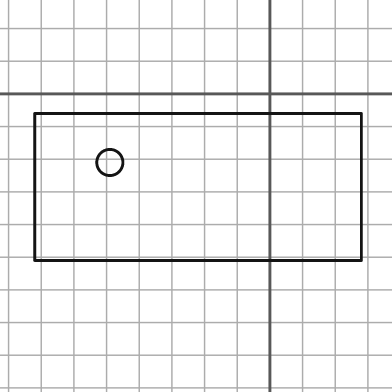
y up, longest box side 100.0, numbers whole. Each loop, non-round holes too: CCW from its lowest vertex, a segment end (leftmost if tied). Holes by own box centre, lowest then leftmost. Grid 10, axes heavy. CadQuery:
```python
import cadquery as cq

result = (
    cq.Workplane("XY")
    .moveTo(-72.0, -51.0)
    .lineTo(28.0, -51.0)
    .lineTo(28.0, -6.0)
    .lineTo(-72.0, -6.0)
    .close()
    .moveTo(-49.0, -21.0)
    .circle(4.0)
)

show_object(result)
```